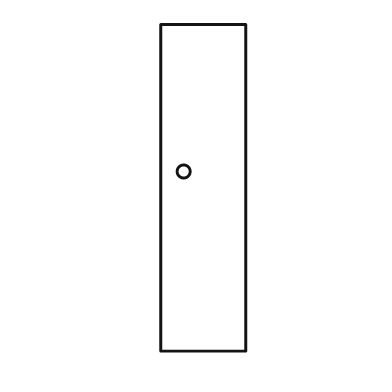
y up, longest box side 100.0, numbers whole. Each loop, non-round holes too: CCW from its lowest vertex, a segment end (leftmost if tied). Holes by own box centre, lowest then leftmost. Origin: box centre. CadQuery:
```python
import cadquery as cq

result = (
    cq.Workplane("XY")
    .moveTo(-13.0, -50.0)
    .lineTo(13.0, -50.0)
    .lineTo(13.0, 50.0)
    .lineTo(-13.0, 50.0)
    .close()
    .moveTo(-6.0, 5.0)
    .circle(2.0)
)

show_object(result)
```